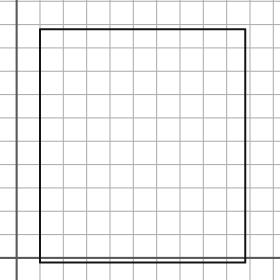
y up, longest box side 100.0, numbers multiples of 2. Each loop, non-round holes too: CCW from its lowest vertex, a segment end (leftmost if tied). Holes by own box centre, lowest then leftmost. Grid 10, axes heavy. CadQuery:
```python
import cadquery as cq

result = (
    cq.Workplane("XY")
    .moveTo(10.0, -2.0)
    .lineTo(98.0, -2.0)
    .lineTo(98.0, 98.0)
    .lineTo(10.0, 98.0)
    .close()
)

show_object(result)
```